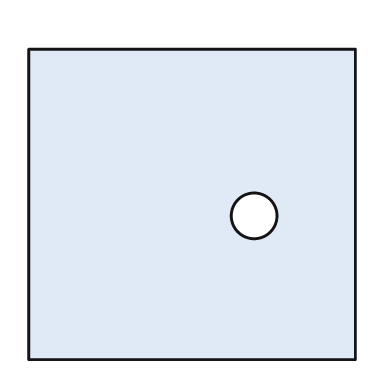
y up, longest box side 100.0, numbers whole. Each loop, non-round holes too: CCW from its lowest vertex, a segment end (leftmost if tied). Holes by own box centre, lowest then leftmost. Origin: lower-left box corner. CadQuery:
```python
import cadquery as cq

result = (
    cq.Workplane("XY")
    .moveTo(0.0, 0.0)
    .lineTo(100.0, 0.0)
    .lineTo(100.0, 95.0)
    .lineTo(0.0, 95.0)
    .close()
    .moveTo(69.0, 44.0)
    .circle(7.0)
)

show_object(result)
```